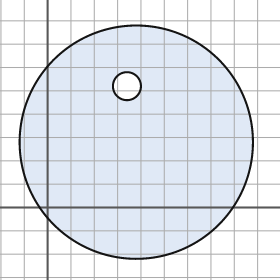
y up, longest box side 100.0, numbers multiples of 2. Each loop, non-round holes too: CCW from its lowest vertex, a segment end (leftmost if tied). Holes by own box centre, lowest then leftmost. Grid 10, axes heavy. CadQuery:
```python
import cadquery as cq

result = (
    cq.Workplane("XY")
    .moveTo(38.0, 28.0)
    .circle(50.0)
    .moveTo(34.0, 52.0)
    .circle(6.0)
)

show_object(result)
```